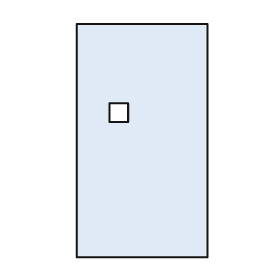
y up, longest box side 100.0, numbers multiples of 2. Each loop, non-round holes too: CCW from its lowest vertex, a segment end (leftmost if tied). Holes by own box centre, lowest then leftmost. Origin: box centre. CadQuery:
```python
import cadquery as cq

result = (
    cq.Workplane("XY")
    .moveTo(-28.0, -50.0)
    .lineTo(28.0, -50.0)
    .lineTo(28.0, 50.0)
    .lineTo(-28.0, 50.0)
    .close()
    .moveTo(-14.0, 8.0)
    .lineTo(-6.0, 8.0)
    .lineTo(-6.0, 16.0)
    .lineTo(-14.0, 16.0)
    .close()
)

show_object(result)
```